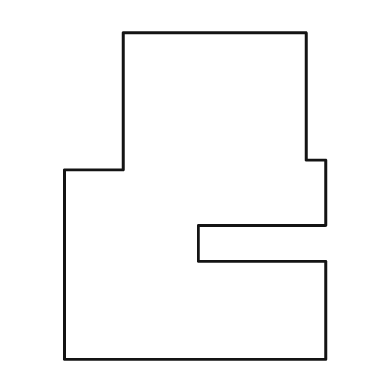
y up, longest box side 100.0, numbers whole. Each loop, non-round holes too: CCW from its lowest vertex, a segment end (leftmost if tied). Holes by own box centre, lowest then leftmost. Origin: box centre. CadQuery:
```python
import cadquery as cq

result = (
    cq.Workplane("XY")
    .moveTo(-40.0, -50.0)
    .lineTo(40.0, -50.0)
    .lineTo(40.0, -20.0)
    .lineTo(1.0, -20.0)
    .lineTo(1.0, -9.0)
    .lineTo(40.0, -9.0)
    .lineTo(40.0, 11.0)
    .lineTo(34.0, 11.0)
    .lineTo(34.0, 50.0)
    .lineTo(-22.0, 50.0)
    .lineTo(-22.0, 8.0)
    .lineTo(-40.0, 8.0)
    .close()
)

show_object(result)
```